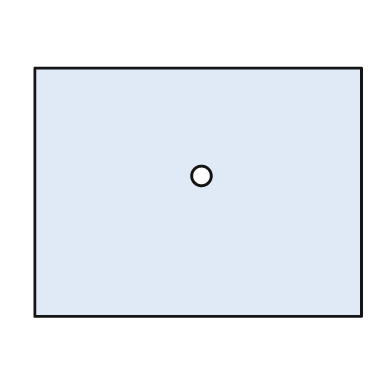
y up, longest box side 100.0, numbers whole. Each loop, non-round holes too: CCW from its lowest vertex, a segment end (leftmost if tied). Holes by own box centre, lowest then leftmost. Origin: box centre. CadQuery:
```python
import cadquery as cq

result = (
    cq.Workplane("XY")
    .moveTo(-50.0, -38.0)
    .lineTo(50.0, -38.0)
    .lineTo(50.0, 38.0)
    .lineTo(-50.0, 38.0)
    .close()
    .moveTo(1.0, 5.0)
    .circle(3.0)
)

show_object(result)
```